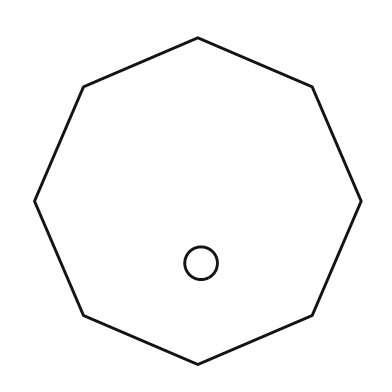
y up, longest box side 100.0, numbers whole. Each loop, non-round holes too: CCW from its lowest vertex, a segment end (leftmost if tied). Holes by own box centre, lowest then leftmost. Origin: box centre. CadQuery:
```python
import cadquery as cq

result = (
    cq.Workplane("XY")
    .moveTo(0.0, -50.0)
    .lineTo(35.0, -35.0)
    .lineTo(50.0, 0.0)
    .lineTo(35.0, 35.0)
    .lineTo(0.0, 50.0)
    .lineTo(-35.0, 35.0)
    .lineTo(-50.0, 0.0)
    .lineTo(-35.0, -35.0)
    .close()
    .moveTo(1.0, -19.0)
    .circle(5.0)
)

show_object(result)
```